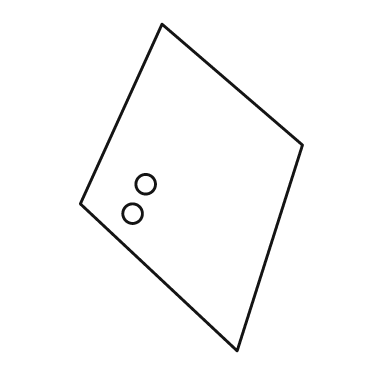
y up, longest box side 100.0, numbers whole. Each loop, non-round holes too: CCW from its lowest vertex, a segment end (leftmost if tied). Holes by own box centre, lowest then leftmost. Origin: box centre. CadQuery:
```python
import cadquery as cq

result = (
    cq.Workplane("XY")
    .moveTo(14.0, -50.0)
    .lineTo(34.0, 13.0)
    .lineTo(-9.0, 50.0)
    .lineTo(-34.0, -5.0)
    .close()
    .moveTo(-18.0, -8.0)
    .circle(3.0)
    .moveTo(-14.0, 1.0)
    .circle(3.0)
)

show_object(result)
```